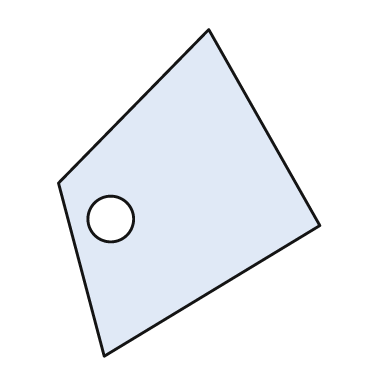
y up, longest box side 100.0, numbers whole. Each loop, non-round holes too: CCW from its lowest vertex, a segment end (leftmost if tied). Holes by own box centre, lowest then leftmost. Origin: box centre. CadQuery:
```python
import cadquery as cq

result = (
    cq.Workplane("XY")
    .moveTo(-26.0, -50.0)
    .lineTo(40.0, -10.0)
    .lineTo(6.0, 50.0)
    .lineTo(-40.0, 3.0)
    .close()
    .moveTo(-24.0, -8.0)
    .circle(7.0)
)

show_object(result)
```